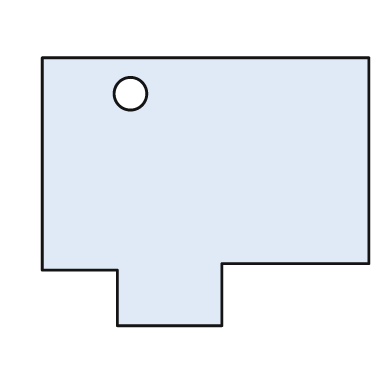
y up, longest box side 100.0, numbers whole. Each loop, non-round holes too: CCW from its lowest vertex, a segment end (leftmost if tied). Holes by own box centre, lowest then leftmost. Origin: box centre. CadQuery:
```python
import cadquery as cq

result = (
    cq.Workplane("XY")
    .moveTo(-27.0, -41.0)
    .lineTo(5.0, -41.0)
    .lineTo(5.0, -22.0)
    .lineTo(50.0, -22.0)
    .lineTo(50.0, 41.0)
    .lineTo(-50.0, 41.0)
    .lineTo(-50.0, -24.0)
    .lineTo(-27.0, -24.0)
    .close()
    .moveTo(-23.0, 30.0)
    .circle(5.0)
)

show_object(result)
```